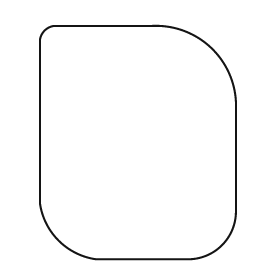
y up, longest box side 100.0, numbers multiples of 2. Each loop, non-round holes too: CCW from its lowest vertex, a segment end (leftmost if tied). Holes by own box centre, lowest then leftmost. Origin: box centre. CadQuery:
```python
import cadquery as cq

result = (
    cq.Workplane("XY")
    .moveTo(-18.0, -50.0)
    .lineTo(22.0, -50.0)
    .threePointArc((36.0, -44.0), (42.0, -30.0))
    .lineTo(42.0, 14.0)
    .threePointArc((32.0, 40.0), (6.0, 50.0))
    .lineTo(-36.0, 50.0)
    .threePointArc((-40.0, 48.0), (-42.0, 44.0))
    .lineTo(-42.0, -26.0)
    .threePointArc((-34.0, -42.0), (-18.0, -50.0))
    .close()
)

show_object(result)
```